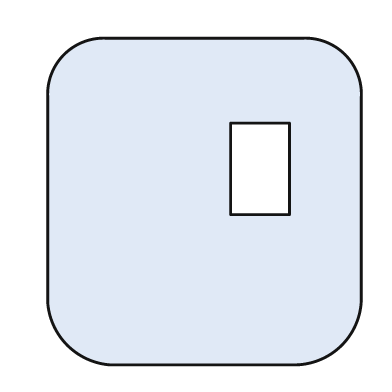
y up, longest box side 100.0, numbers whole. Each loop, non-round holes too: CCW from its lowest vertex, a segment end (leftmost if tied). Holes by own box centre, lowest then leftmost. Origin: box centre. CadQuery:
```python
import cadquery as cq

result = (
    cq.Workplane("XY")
    .moveTo(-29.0, -50.0)
    .lineTo(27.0, -50.0)
    .threePointArc((42.0, -44.0), (48.0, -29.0))
    .lineTo(48.0, 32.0)
    .threePointArc((43.0, 45.0), (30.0, 50.0))
    .lineTo(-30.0, 50.0)
    .threePointArc((-43.0, 45.0), (-48.0, 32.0))
    .lineTo(-48.0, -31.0)
    .threePointArc((-42.0, -44.0), (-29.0, -50.0))
    .close()
    .moveTo(8.0, -4.0)
    .lineTo(26.0, -4.0)
    .lineTo(26.0, 24.0)
    .lineTo(8.0, 24.0)
    .close()
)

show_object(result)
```